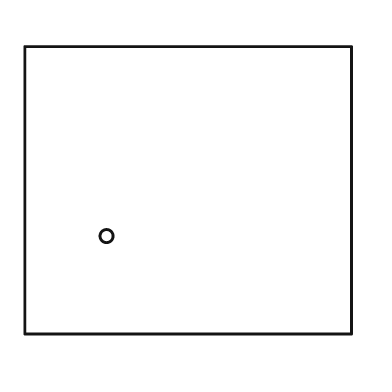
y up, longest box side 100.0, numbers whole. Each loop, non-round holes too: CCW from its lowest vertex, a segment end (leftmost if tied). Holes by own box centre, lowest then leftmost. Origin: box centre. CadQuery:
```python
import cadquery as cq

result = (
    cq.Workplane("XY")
    .moveTo(-50.0, -44.0)
    .lineTo(50.0, -44.0)
    .lineTo(50.0, 44.0)
    .lineTo(-50.0, 44.0)
    .close()
    .moveTo(-25.0, -14.0)
    .circle(2.0)
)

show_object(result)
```